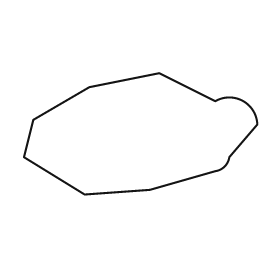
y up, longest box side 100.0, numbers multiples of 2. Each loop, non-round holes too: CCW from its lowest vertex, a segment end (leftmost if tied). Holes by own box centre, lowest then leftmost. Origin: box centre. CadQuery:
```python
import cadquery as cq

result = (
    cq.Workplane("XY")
    .moveTo(-24.0, -26.0)
    .lineTo(4.0, -24.0)
    .lineTo(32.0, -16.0)
    .threePointArc((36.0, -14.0), (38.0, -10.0))
    .lineTo(50.0, 4.0)
    .threePointArc((44.0, 14.0), (32.0, 14.0))
    .lineTo(8.0, 26.0)
    .lineTo(-22.0, 20.0)
    .lineTo(-46.0, 6.0)
    .lineTo(-50.0, -10.0)
    .close()
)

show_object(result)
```